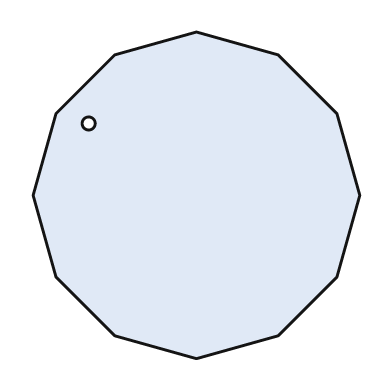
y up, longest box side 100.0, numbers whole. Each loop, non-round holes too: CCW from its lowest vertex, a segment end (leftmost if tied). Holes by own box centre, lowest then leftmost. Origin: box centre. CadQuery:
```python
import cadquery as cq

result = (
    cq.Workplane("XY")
    .moveTo(0.0, -50.0)
    .lineTo(25.0, -43.0)
    .lineTo(43.0, -25.0)
    .lineTo(50.0, 0.0)
    .lineTo(43.0, 25.0)
    .lineTo(25.0, 43.0)
    .lineTo(0.0, 50.0)
    .lineTo(-25.0, 43.0)
    .lineTo(-43.0, 25.0)
    .lineTo(-50.0, 0.0)
    .lineTo(-43.0, -25.0)
    .lineTo(-25.0, -43.0)
    .close()
    .moveTo(-33.0, 22.0)
    .circle(2.0)
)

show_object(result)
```